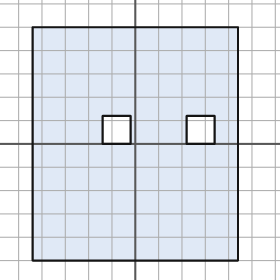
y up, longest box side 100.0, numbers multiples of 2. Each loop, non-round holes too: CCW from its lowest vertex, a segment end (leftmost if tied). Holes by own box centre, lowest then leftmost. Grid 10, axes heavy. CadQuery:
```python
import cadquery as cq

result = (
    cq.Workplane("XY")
    .moveTo(-44.0, -50.0)
    .lineTo(44.0, -50.0)
    .lineTo(44.0, 50.0)
    .lineTo(-44.0, 50.0)
    .close()
    .moveTo(-14.0, 0.0)
    .lineTo(-2.0, 0.0)
    .lineTo(-2.0, 12.0)
    .lineTo(-14.0, 12.0)
    .close()
    .moveTo(22.0, 0.0)
    .lineTo(34.0, 0.0)
    .lineTo(34.0, 12.0)
    .lineTo(22.0, 12.0)
    .close()
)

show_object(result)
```